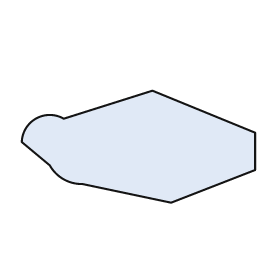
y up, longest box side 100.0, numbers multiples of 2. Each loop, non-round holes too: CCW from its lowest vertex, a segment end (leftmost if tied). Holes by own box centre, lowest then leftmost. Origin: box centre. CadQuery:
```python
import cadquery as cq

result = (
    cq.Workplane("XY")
    .moveTo(14.0, -24.0)
    .lineTo(50.0, -10.0)
    .lineTo(50.0, 6.0)
    .lineTo(6.0, 24.0)
    .lineTo(-32.0, 12.0)
    .threePointArc((-44.0, 12.0), (-50.0, 2.0))
    .lineTo(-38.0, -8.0)
    .threePointArc((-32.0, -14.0), (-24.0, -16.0))
    .close()
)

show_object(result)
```